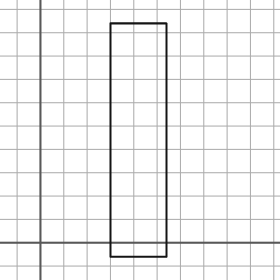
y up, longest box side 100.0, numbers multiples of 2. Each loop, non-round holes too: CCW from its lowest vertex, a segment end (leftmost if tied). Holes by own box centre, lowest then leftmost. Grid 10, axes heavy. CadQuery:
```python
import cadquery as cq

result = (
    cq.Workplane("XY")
    .moveTo(30.0, -6.0)
    .lineTo(54.0, -6.0)
    .lineTo(54.0, 94.0)
    .lineTo(30.0, 94.0)
    .close()
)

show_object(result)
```